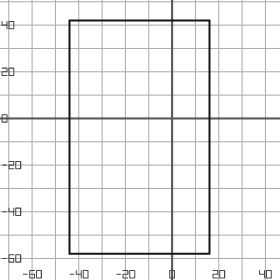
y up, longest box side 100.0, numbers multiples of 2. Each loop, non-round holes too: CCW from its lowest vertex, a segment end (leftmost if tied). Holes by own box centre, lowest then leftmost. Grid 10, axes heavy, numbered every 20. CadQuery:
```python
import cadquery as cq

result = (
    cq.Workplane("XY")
    .moveTo(-44.0, -58.0)
    .lineTo(16.0, -58.0)
    .lineTo(16.0, 42.0)
    .lineTo(-44.0, 42.0)
    .close()
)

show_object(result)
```